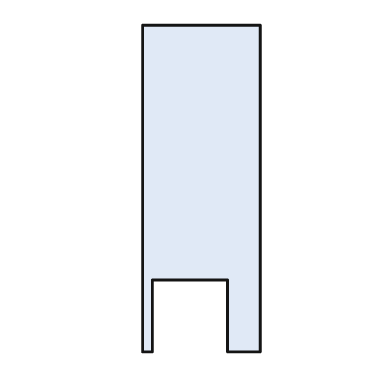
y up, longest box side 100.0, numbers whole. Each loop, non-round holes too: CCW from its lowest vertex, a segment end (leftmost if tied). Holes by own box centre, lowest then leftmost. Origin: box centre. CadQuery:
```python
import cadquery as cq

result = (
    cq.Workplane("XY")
    .moveTo(-18.0, -50.0)
    .lineTo(-15.0, -50.0)
    .lineTo(-15.0, -28.0)
    .lineTo(8.0, -28.0)
    .lineTo(8.0, -50.0)
    .lineTo(18.0, -50.0)
    .lineTo(18.0, 50.0)
    .lineTo(-18.0, 50.0)
    .close()
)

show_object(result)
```